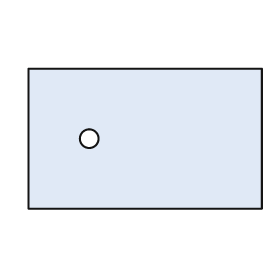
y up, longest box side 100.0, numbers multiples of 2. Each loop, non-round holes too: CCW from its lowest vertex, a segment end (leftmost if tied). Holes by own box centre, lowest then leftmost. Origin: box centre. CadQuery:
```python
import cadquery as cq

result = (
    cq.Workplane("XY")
    .moveTo(-50.0, -30.0)
    .lineTo(50.0, -30.0)
    .lineTo(50.0, 30.0)
    .lineTo(-50.0, 30.0)
    .close()
    .moveTo(-24.0, 0.0)
    .circle(4.0)
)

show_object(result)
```